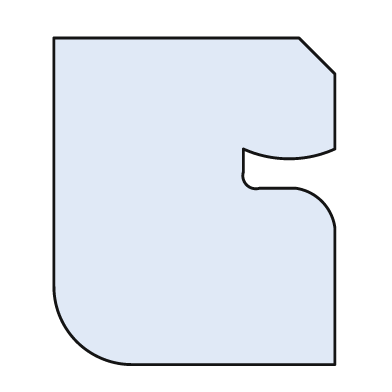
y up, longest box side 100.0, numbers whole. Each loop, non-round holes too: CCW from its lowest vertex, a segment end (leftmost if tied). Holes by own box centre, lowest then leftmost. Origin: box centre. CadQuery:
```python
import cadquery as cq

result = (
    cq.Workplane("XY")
    .moveTo(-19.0, -50.0)
    .lineTo(43.0, -50.0)
    .lineTo(43.0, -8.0)
    .threePointArc((39.0, 0.0), (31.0, 4.0))
    .lineTo(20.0, 4.0)
    .threePointArc((16.0, 5.0), (15.0, 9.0))
    .lineTo(15.0, 16.0)
    .threePointArc((29.0, 13.0), (43.0, 16.0))
    .lineTo(43.0, 39.0)
    .lineTo(32.0, 50.0)
    .lineTo(-43.0, 50.0)
    .lineTo(-43.0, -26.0)
    .threePointArc((-36.0, -43.0), (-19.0, -50.0))
    .close()
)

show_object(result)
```